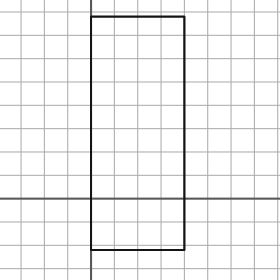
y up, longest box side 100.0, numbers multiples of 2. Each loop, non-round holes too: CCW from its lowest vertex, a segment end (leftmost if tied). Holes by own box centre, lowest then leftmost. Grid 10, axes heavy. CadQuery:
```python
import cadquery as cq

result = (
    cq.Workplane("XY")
    .moveTo(0.0, -22.0)
    .lineTo(40.0, -22.0)
    .lineTo(40.0, 78.0)
    .lineTo(0.0, 78.0)
    .close()
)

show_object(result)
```